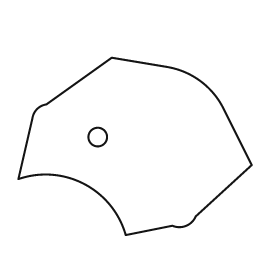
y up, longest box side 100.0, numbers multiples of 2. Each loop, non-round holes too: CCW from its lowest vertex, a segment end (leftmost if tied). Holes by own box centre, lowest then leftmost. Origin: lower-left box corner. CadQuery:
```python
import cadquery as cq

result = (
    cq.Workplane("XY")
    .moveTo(46.0, 0.0)
    .lineTo(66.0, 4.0)
    .threePointArc((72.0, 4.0), (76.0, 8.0))
    .lineTo(100.0, 30.0)
    .lineTo(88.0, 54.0)
    .threePointArc((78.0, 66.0), (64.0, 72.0))
    .lineTo(40.0, 76.0)
    .lineTo(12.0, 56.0)
    .threePointArc((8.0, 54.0), (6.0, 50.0))
    .lineTo(0.0, 24.0)
    .threePointArc((28.0, 22.0), (46.0, 0.0))
    .close()
    .moveTo(34.0, 42.0)
    .circle(4.0)
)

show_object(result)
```